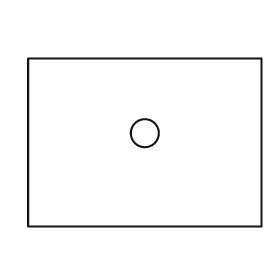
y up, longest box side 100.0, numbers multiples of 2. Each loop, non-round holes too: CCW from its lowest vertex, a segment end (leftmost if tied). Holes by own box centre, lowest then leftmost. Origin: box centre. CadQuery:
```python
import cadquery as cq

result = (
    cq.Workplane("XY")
    .moveTo(-50.0, -36.0)
    .lineTo(50.0, -36.0)
    .lineTo(50.0, 36.0)
    .lineTo(-50.0, 36.0)
    .close()
    .moveTo(0.0, 4.0)
    .circle(6.0)
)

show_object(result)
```